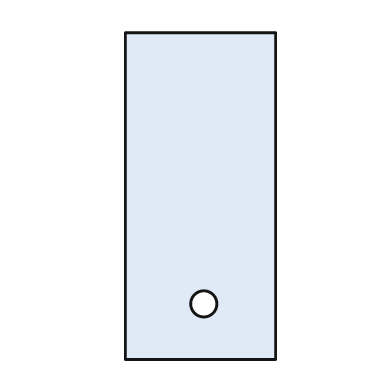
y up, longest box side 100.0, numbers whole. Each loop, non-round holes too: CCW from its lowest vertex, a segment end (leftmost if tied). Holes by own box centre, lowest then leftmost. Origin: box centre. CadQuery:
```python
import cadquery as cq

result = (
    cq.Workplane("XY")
    .moveTo(-23.0, -50.0)
    .lineTo(23.0, -50.0)
    .lineTo(23.0, 50.0)
    .lineTo(-23.0, 50.0)
    .close()
    .moveTo(1.0, -33.0)
    .circle(4.0)
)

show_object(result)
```